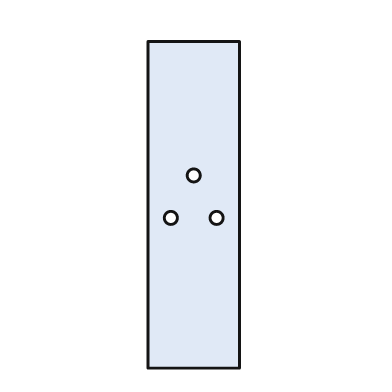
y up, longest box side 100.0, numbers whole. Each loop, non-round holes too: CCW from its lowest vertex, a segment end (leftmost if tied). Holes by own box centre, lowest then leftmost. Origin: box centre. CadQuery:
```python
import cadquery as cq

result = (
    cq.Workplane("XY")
    .moveTo(-14.0, -50.0)
    .lineTo(14.0, -50.0)
    .lineTo(14.0, 50.0)
    .lineTo(-14.0, 50.0)
    .close()
    .moveTo(-7.0, -4.0)
    .circle(2.0)
    .moveTo(7.0, -4.0)
    .circle(2.0)
    .moveTo(0.0, 9.0)
    .circle(2.0)
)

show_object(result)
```